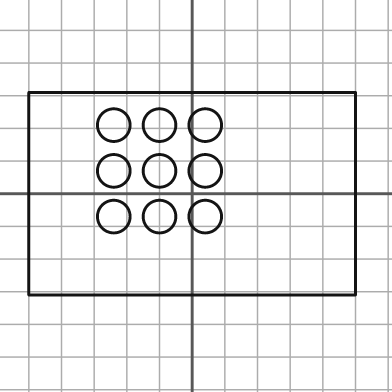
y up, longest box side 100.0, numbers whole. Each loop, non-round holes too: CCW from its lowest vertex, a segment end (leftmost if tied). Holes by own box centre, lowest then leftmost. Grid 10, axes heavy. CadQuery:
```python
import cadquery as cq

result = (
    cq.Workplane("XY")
    .moveTo(-50.0, -31.0)
    .lineTo(50.0, -31.0)
    .lineTo(50.0, 31.0)
    .lineTo(-50.0, 31.0)
    .close()
    .moveTo(-24.0, -7.0)
    .circle(5.0)
    .moveTo(-10.0, -7.0)
    .circle(5.0)
    .moveTo(4.0, -7.0)
    .circle(5.0)
    .moveTo(-24.0, 7.0)
    .circle(5.0)
    .moveTo(-10.0, 7.0)
    .circle(5.0)
    .moveTo(4.0, 7.0)
    .circle(5.0)
    .moveTo(-24.0, 21.0)
    .circle(5.0)
    .moveTo(-10.0, 21.0)
    .circle(5.0)
    .moveTo(4.0, 21.0)
    .circle(5.0)
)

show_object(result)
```